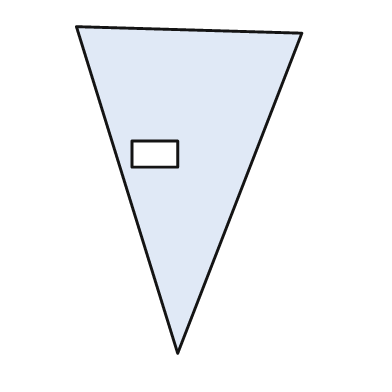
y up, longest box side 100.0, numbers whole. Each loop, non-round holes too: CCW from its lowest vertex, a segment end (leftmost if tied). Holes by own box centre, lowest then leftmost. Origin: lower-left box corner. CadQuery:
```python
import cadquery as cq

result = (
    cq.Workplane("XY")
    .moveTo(31.0, 0.0)
    .lineTo(69.0, 98.0)
    .lineTo(0.0, 100.0)
    .close()
    .moveTo(17.0, 57.0)
    .lineTo(31.0, 57.0)
    .lineTo(31.0, 65.0)
    .lineTo(17.0, 65.0)
    .close()
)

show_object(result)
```